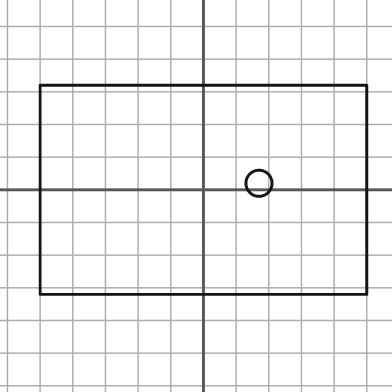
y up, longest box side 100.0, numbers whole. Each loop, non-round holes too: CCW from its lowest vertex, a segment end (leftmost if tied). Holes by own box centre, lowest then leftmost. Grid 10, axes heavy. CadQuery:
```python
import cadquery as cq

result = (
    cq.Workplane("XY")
    .moveTo(-50.0, -32.0)
    .lineTo(50.0, -32.0)
    .lineTo(50.0, 32.0)
    .lineTo(-50.0, 32.0)
    .close()
    .moveTo(17.0, 2.0)
    .circle(4.0)
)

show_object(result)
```